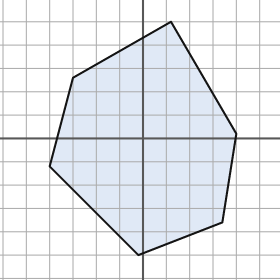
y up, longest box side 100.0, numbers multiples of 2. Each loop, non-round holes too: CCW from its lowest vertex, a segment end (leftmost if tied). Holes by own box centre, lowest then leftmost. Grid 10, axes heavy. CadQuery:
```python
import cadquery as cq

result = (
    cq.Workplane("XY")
    .moveTo(-2.0, -50.0)
    .lineTo(34.0, -36.0)
    .lineTo(40.0, 2.0)
    .lineTo(12.0, 50.0)
    .lineTo(-30.0, 26.0)
    .lineTo(-40.0, -12.0)
    .close()
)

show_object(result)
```